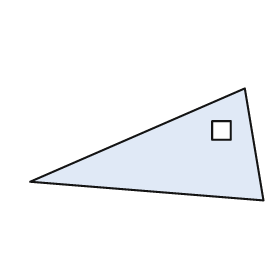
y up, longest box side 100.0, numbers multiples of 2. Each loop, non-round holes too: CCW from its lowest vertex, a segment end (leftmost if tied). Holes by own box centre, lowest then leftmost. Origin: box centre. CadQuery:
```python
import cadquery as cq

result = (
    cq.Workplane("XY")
    .moveTo(50.0, -24.0)
    .lineTo(42.0, 24.0)
    .lineTo(-50.0, -16.0)
    .close()
    .moveTo(28.0, 2.0)
    .lineTo(36.0, 2.0)
    .lineTo(36.0, 10.0)
    .lineTo(28.0, 10.0)
    .close()
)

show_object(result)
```